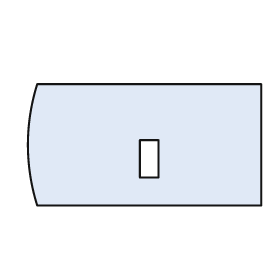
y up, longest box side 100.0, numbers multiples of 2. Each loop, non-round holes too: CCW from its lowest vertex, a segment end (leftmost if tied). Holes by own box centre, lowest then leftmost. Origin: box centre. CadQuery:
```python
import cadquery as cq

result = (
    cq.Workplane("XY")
    .moveTo(-46.0, -26.0)
    .lineTo(50.0, -26.0)
    .lineTo(50.0, 26.0)
    .lineTo(-46.0, 26.0)
    .threePointArc((-50.0, 0.0), (-46.0, -26.0))
    .close()
    .moveTo(-2.0, -14.0)
    .lineTo(6.0, -14.0)
    .lineTo(6.0, 2.0)
    .lineTo(-2.0, 2.0)
    .close()
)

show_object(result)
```